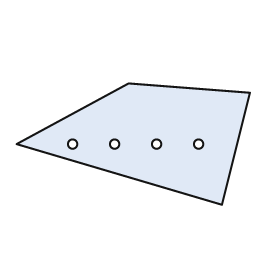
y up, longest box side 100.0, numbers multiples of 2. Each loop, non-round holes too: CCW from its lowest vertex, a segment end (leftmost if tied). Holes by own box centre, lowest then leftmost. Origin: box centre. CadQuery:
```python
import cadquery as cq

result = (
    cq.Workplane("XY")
    .moveTo(38.0, -26.0)
    .lineTo(50.0, 22.0)
    .lineTo(-2.0, 26.0)
    .lineTo(-50.0, 0.0)
    .close()
    .moveTo(-26.0, 0.0)
    .circle(2.0)
    .moveTo(-8.0, 0.0)
    .circle(2.0)
    .moveTo(10.0, 0.0)
    .circle(2.0)
    .moveTo(28.0, 0.0)
    .circle(2.0)
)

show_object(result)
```